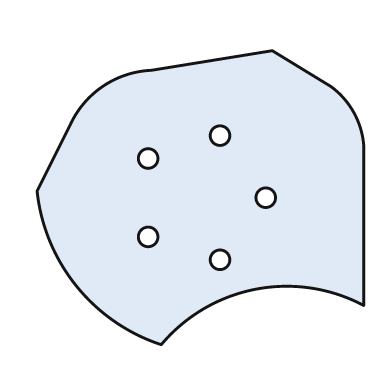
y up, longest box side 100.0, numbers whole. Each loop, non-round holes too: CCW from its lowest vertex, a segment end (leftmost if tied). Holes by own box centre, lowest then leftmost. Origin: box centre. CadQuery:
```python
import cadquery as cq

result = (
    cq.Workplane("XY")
    .moveTo(-12.0, -45.0)
    .threePointArc((17.0, -28.0), (50.0, -33.0))
    .lineTo(50.0, 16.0)
    .threePointArc((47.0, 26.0), (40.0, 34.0))
    .lineTo(22.0, 45.0)
    .lineTo(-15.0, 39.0)
    .threePointArc((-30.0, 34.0), (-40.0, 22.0))
    .lineTo(-50.0, 2.0)
    .threePointArc((-38.0, -27.0), (-12.0, -45.0))
    .close()
    .moveTo(6.0, -19.0)
    .circle(3.0)
    .moveTo(-16.0, -12.0)
    .circle(3.0)
    .moveTo(20.0, 0.0)
    .circle(3.0)
    .moveTo(-16.0, 12.0)
    .circle(3.0)
    .moveTo(6.0, 19.0)
    .circle(3.0)
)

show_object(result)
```